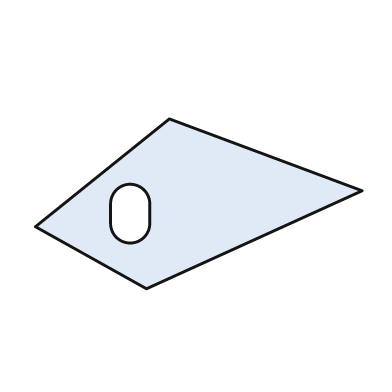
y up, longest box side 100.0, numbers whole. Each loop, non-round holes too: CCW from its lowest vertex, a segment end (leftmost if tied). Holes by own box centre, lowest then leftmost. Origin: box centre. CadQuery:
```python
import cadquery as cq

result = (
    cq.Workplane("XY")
    .moveTo(-16.0, -26.0)
    .lineTo(50.0, 4.0)
    .lineTo(-9.0, 26.0)
    .lineTo(-50.0, -7.0)
    .close()
    .moveTo(-27.0, -6.0)
    .threePointArc((-21.0, -12.0), (-15.0, -6.0))
    .lineTo(-15.0, 0.0)
    .threePointArc((-21.0, 6.0), (-27.0, 0.0))
    .close()
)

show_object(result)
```